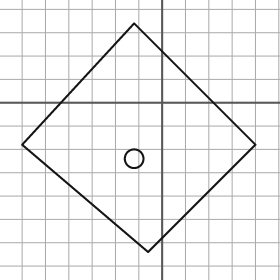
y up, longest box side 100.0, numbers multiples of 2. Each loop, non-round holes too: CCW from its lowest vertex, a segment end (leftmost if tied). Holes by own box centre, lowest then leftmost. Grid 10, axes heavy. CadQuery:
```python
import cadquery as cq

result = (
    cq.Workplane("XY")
    .moveTo(-6.0, -64.0)
    .lineTo(40.0, -18.0)
    .lineTo(-12.0, 34.0)
    .lineTo(-60.0, -18.0)
    .close()
    .moveTo(-12.0, -24.0)
    .circle(4.0)
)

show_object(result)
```